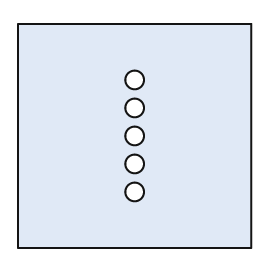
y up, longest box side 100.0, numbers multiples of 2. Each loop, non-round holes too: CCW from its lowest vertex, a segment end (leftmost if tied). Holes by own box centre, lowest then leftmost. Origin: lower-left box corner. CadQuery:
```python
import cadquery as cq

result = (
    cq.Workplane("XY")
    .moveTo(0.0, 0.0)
    .lineTo(100.0, 0.0)
    .lineTo(100.0, 96.0)
    .lineTo(0.0, 96.0)
    .close()
    .moveTo(50.0, 24.0)
    .circle(4.0)
    .moveTo(50.0, 36.0)
    .circle(4.0)
    .moveTo(50.0, 48.0)
    .circle(4.0)
    .moveTo(50.0, 60.0)
    .circle(4.0)
    .moveTo(50.0, 72.0)
    .circle(4.0)
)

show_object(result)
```